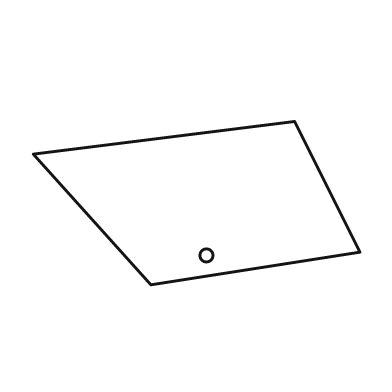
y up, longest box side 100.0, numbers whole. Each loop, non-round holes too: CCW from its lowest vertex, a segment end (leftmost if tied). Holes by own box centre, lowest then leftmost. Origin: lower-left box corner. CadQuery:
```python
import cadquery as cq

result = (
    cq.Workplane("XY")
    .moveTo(36.0, 0.0)
    .lineTo(100.0, 10.0)
    .lineTo(80.0, 50.0)
    .lineTo(0.0, 40.0)
    .close()
    .moveTo(53.0, 9.0)
    .circle(2.0)
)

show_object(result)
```